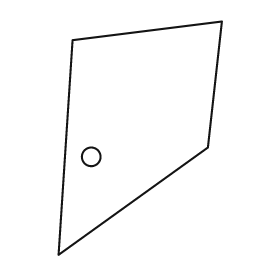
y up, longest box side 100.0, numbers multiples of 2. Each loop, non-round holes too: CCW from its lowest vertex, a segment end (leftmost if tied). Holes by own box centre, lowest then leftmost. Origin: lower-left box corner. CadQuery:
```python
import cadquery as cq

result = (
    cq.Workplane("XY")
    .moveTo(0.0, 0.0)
    .lineTo(64.0, 46.0)
    .lineTo(70.0, 100.0)
    .lineTo(6.0, 92.0)
    .close()
    .moveTo(14.0, 42.0)
    .circle(4.0)
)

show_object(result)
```